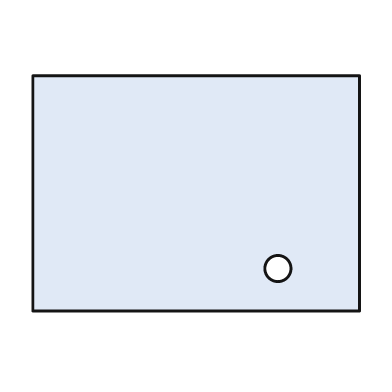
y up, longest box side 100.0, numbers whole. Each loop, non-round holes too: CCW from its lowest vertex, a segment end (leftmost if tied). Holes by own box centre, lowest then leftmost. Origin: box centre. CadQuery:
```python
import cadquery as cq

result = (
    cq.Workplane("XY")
    .moveTo(-50.0, -36.0)
    .lineTo(50.0, -36.0)
    .lineTo(50.0, 36.0)
    .lineTo(-50.0, 36.0)
    .close()
    .moveTo(25.0, -23.0)
    .circle(4.0)
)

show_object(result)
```